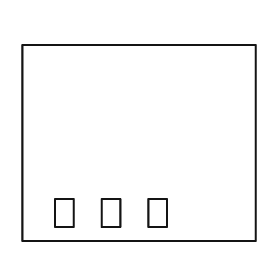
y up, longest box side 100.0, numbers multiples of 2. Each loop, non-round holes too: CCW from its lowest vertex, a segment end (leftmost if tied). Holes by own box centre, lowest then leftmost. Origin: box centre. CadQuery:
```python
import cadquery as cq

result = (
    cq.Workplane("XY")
    .moveTo(-50.0, -42.0)
    .lineTo(50.0, -42.0)
    .lineTo(50.0, 42.0)
    .lineTo(-50.0, 42.0)
    .close()
    .moveTo(-36.0, -36.0)
    .lineTo(-28.0, -36.0)
    .lineTo(-28.0, -24.0)
    .lineTo(-36.0, -24.0)
    .close()
    .moveTo(-16.0, -36.0)
    .lineTo(-8.0, -36.0)
    .lineTo(-8.0, -24.0)
    .lineTo(-16.0, -24.0)
    .close()
    .moveTo(4.0, -36.0)
    .lineTo(12.0, -36.0)
    .lineTo(12.0, -24.0)
    .lineTo(4.0, -24.0)
    .close()
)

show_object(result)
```